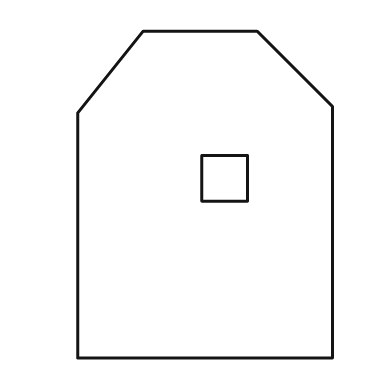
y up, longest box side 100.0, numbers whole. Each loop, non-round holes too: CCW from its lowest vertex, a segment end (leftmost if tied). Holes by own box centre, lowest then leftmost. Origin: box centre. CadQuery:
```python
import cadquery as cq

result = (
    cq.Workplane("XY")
    .moveTo(-39.0, -50.0)
    .lineTo(39.0, -50.0)
    .lineTo(39.0, 27.0)
    .lineTo(16.0, 50.0)
    .lineTo(-19.0, 50.0)
    .lineTo(-39.0, 25.0)
    .close()
    .moveTo(-1.0, -2.0)
    .lineTo(13.0, -2.0)
    .lineTo(13.0, 12.0)
    .lineTo(-1.0, 12.0)
    .close()
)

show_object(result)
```